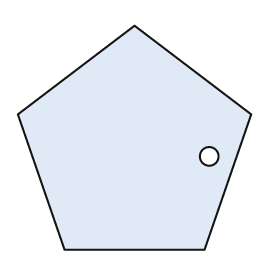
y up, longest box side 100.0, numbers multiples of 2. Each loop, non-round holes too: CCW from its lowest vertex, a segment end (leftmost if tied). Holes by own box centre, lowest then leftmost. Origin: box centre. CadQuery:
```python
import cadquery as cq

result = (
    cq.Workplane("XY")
    .moveTo(-30.0, -48.0)
    .lineTo(30.0, -48.0)
    .lineTo(50.0, 10.0)
    .lineTo(0.0, 48.0)
    .lineTo(-50.0, 10.0)
    .close()
    .moveTo(32.0, -8.0)
    .circle(4.0)
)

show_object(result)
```